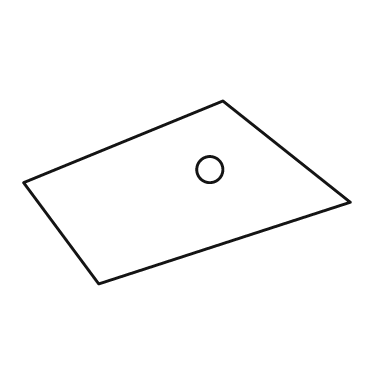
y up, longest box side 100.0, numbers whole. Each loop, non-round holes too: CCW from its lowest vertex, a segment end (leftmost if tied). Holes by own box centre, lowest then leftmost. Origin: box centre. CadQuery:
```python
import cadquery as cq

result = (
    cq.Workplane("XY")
    .moveTo(-27.0, -28.0)
    .lineTo(50.0, -3.0)
    .lineTo(11.0, 28.0)
    .lineTo(-50.0, 3.0)
    .close()
    .moveTo(7.0, 7.0)
    .circle(4.0)
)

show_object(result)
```